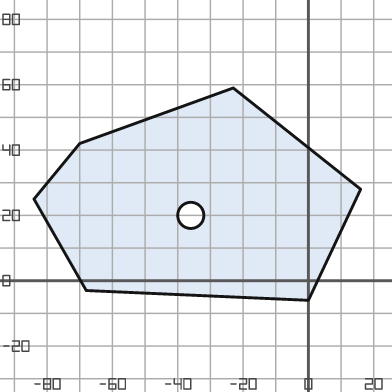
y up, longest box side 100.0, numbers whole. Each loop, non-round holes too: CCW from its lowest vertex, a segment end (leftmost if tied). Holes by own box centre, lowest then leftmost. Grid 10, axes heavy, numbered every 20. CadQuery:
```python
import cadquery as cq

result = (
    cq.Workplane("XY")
    .moveTo(0.0, -6.0)
    .lineTo(16.0, 28.0)
    .lineTo(-23.0, 59.0)
    .lineTo(-70.0, 42.0)
    .lineTo(-84.0, 25.0)
    .lineTo(-68.0, -3.0)
    .close()
    .moveTo(-36.0, 20.0)
    .circle(4.0)
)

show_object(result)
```